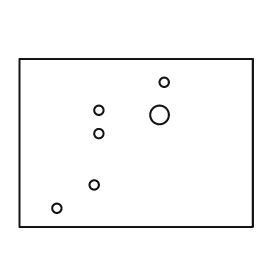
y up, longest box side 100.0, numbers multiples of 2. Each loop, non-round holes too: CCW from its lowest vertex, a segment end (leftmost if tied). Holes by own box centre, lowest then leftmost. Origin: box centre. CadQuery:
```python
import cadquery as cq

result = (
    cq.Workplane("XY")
    .moveTo(-50.0, -36.0)
    .lineTo(50.0, -36.0)
    .lineTo(50.0, 36.0)
    .lineTo(-50.0, 36.0)
    .close()
    .moveTo(-34.0, -28.0)
    .circle(2.0)
    .moveTo(-18.0, -18.0)
    .circle(2.0)
    .moveTo(-16.0, 4.0)
    .circle(2.0)
    .moveTo(10.0, 12.0)
    .circle(4.0)
    .moveTo(-16.0, 14.0)
    .circle(2.0)
    .moveTo(12.0, 26.0)
    .circle(2.0)
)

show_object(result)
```